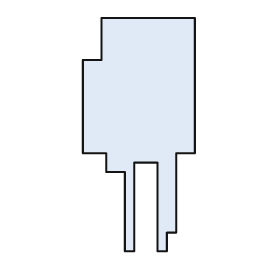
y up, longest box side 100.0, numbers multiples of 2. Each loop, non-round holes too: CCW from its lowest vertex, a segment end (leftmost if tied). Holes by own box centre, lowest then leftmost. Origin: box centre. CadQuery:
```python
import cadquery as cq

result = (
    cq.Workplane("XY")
    .moveTo(-6.0, -50.0)
    .lineTo(-2.0, -50.0)
    .lineTo(-2.0, -12.0)
    .lineTo(8.0, -12.0)
    .lineTo(8.0, -50.0)
    .lineTo(12.0, -50.0)
    .lineTo(12.0, -42.0)
    .lineTo(16.0, -42.0)
    .lineTo(16.0, -8.0)
    .lineTo(24.0, -8.0)
    .lineTo(24.0, 50.0)
    .lineTo(-16.0, 50.0)
    .lineTo(-16.0, 32.0)
    .lineTo(-24.0, 32.0)
    .lineTo(-24.0, -8.0)
    .lineTo(-14.0, -8.0)
    .lineTo(-14.0, -16.0)
    .lineTo(-6.0, -16.0)
    .close()
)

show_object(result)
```